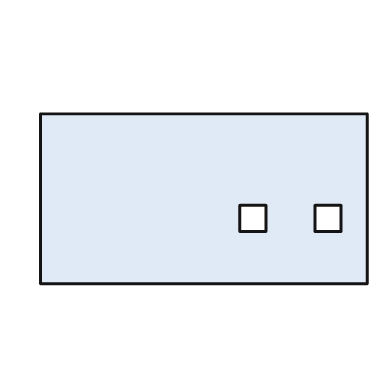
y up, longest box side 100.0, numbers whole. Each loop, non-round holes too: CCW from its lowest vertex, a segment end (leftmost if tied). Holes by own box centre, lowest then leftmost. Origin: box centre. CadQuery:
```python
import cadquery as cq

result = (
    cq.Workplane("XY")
    .moveTo(-50.0, -26.0)
    .lineTo(50.0, -26.0)
    .lineTo(50.0, 26.0)
    .lineTo(-50.0, 26.0)
    .close()
    .moveTo(11.0, -10.0)
    .lineTo(19.0, -10.0)
    .lineTo(19.0, -2.0)
    .lineTo(11.0, -2.0)
    .close()
    .moveTo(34.0, -10.0)
    .lineTo(42.0, -10.0)
    .lineTo(42.0, -2.0)
    .lineTo(34.0, -2.0)
    .close()
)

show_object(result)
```